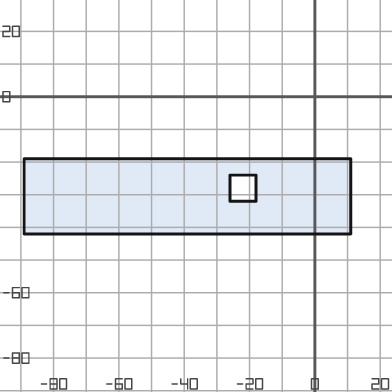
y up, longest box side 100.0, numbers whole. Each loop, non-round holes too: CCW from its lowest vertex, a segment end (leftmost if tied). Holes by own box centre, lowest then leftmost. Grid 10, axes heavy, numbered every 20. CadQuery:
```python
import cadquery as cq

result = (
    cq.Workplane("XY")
    .moveTo(-89.0, -42.0)
    .lineTo(11.0, -42.0)
    .lineTo(11.0, -19.0)
    .lineTo(-89.0, -19.0)
    .close()
    .moveTo(-26.0, -32.0)
    .lineTo(-18.0, -32.0)
    .lineTo(-18.0, -24.0)
    .lineTo(-26.0, -24.0)
    .close()
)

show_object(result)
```